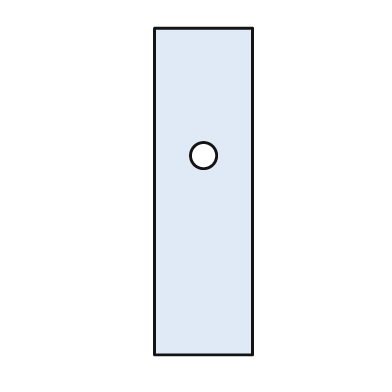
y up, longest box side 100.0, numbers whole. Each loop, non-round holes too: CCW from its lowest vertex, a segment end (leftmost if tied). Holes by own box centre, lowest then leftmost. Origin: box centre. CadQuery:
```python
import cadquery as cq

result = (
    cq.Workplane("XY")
    .moveTo(-15.0, -50.0)
    .lineTo(15.0, -50.0)
    .lineTo(15.0, 50.0)
    .lineTo(-15.0, 50.0)
    .close()
    .moveTo(0.0, 11.0)
    .circle(4.0)
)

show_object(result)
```